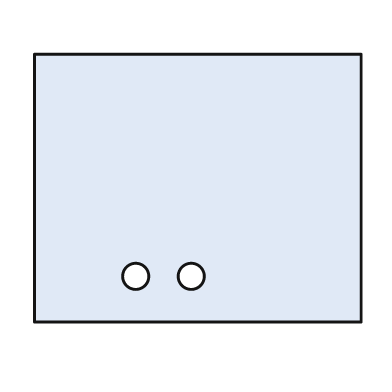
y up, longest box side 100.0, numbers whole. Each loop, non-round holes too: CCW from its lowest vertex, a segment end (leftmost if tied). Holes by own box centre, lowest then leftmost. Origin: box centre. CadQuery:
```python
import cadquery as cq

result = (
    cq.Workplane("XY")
    .moveTo(-50.0, -41.0)
    .lineTo(50.0, -41.0)
    .lineTo(50.0, 41.0)
    .lineTo(-50.0, 41.0)
    .close()
    .moveTo(-19.0, -27.0)
    .circle(4.0)
    .moveTo(-2.0, -27.0)
    .circle(4.0)
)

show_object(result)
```